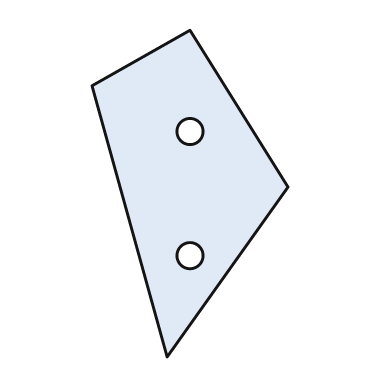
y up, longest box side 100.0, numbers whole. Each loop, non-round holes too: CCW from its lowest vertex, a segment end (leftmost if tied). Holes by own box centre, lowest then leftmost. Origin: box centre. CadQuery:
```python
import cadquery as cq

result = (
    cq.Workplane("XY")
    .moveTo(-7.0, -50.0)
    .lineTo(30.0, 2.0)
    .lineTo(0.0, 50.0)
    .lineTo(-30.0, 33.0)
    .close()
    .moveTo(0.0, -19.0)
    .circle(4.0)
    .moveTo(0.0, 19.0)
    .circle(4.0)
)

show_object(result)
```